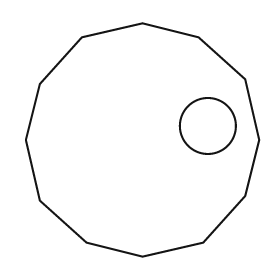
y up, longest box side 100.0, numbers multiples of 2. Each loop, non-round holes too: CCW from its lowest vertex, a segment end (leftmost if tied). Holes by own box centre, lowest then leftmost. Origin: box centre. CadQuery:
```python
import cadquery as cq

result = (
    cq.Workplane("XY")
    .moveTo(0.0, -50.0)
    .lineTo(26.0, -44.0)
    .lineTo(44.0, -24.0)
    .lineTo(50.0, 0.0)
    .lineTo(44.0, 26.0)
    .lineTo(24.0, 44.0)
    .lineTo(0.0, 50.0)
    .lineTo(-26.0, 44.0)
    .lineTo(-44.0, 24.0)
    .lineTo(-50.0, 0.0)
    .lineTo(-44.0, -26.0)
    .lineTo(-24.0, -44.0)
    .close()
    .moveTo(28.0, 6.0)
    .circle(12.0)
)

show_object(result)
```